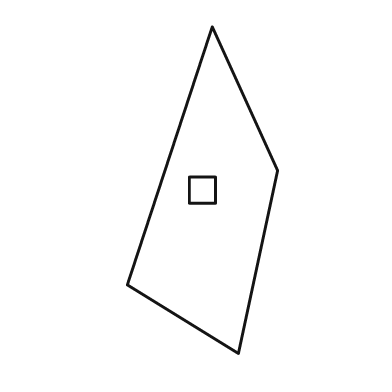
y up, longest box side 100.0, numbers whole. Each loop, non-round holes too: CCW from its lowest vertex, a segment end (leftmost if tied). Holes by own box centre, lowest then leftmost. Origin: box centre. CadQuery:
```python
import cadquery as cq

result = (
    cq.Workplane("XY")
    .moveTo(11.0, -50.0)
    .lineTo(23.0, 6.0)
    .lineTo(3.0, 50.0)
    .lineTo(-23.0, -29.0)
    .close()
    .moveTo(-4.0, -4.0)
    .lineTo(4.0, -4.0)
    .lineTo(4.0, 4.0)
    .lineTo(-4.0, 4.0)
    .close()
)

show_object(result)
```